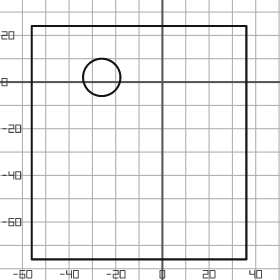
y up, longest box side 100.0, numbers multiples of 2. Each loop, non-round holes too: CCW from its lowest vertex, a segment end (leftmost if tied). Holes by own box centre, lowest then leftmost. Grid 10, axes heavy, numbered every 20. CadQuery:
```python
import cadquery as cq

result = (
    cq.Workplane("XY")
    .moveTo(-56.0, -76.0)
    .lineTo(36.0, -76.0)
    .lineTo(36.0, 24.0)
    .lineTo(-56.0, 24.0)
    .close()
    .moveTo(-26.0, 2.0)
    .circle(8.0)
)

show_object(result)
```